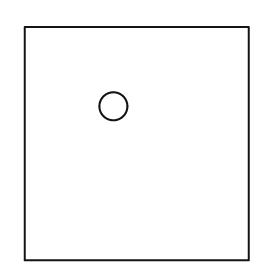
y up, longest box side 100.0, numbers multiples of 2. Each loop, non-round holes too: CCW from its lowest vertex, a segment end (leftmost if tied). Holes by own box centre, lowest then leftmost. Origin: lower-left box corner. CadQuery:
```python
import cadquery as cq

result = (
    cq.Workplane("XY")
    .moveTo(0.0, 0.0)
    .lineTo(96.0, 0.0)
    .lineTo(96.0, 100.0)
    .lineTo(0.0, 100.0)
    .close()
    .moveTo(38.0, 66.0)
    .circle(6.0)
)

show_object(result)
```